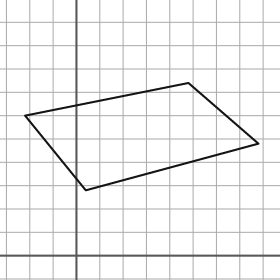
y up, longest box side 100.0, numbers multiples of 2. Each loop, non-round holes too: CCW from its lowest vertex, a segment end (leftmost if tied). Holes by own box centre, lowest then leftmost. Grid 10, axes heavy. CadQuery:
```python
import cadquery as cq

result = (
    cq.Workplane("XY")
    .moveTo(4.0, 28.0)
    .lineTo(78.0, 48.0)
    .lineTo(48.0, 74.0)
    .lineTo(-22.0, 60.0)
    .close()
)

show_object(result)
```